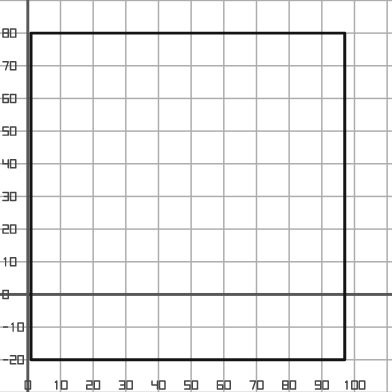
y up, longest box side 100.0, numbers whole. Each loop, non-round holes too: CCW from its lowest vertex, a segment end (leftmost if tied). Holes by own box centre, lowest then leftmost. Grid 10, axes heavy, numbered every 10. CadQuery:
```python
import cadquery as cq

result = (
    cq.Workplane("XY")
    .moveTo(1.0, -20.0)
    .lineTo(97.0, -20.0)
    .lineTo(97.0, 80.0)
    .lineTo(1.0, 80.0)
    .close()
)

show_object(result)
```